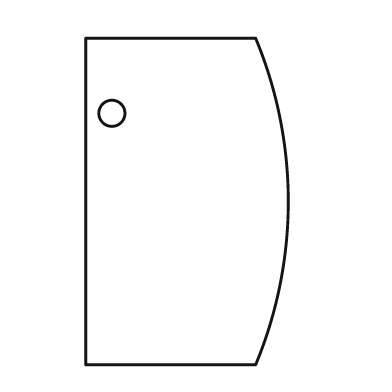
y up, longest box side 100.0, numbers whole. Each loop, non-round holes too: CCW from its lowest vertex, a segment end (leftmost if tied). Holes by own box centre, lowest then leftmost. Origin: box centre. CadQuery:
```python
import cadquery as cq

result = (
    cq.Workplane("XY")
    .moveTo(-31.0, -50.0)
    .lineTo(21.0, -50.0)
    .threePointArc((31.0, 0.0), (21.0, 50.0))
    .lineTo(-31.0, 50.0)
    .close()
    .moveTo(-23.0, 27.0)
    .circle(4.0)
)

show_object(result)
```